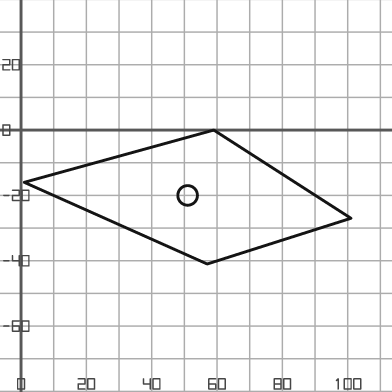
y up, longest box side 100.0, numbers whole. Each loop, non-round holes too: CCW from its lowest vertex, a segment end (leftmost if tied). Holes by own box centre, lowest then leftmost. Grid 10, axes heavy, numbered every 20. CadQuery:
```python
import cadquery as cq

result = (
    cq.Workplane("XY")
    .moveTo(57.0, -41.0)
    .lineTo(101.0, -27.0)
    .lineTo(59.0, 0.0)
    .lineTo(1.0, -16.0)
    .close()
    .moveTo(51.0, -20.0)
    .circle(3.0)
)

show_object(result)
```